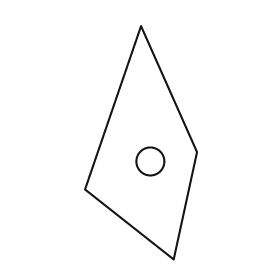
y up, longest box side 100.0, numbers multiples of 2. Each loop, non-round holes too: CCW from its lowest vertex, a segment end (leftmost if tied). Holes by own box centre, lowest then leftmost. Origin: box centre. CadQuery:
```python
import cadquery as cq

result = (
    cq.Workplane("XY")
    .moveTo(14.0, -50.0)
    .lineTo(24.0, -4.0)
    .lineTo(0.0, 50.0)
    .lineTo(-24.0, -20.0)
    .close()
    .moveTo(4.0, -8.0)
    .circle(6.0)
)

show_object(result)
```